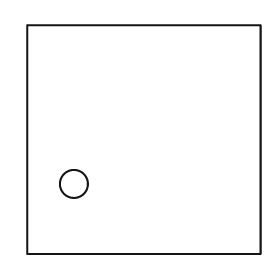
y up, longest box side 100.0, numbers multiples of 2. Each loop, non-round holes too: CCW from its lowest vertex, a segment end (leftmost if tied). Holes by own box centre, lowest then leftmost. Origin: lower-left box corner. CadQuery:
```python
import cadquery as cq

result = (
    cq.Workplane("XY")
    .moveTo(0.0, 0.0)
    .lineTo(100.0, 0.0)
    .lineTo(100.0, 98.0)
    .lineTo(0.0, 98.0)
    .close()
    .moveTo(20.0, 30.0)
    .circle(6.0)
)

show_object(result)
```